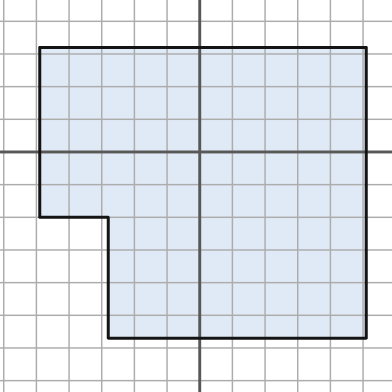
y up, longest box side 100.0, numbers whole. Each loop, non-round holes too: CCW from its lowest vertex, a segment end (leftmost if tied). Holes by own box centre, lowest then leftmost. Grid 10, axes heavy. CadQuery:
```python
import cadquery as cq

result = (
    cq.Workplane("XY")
    .moveTo(-28.0, -57.0)
    .lineTo(51.0, -57.0)
    .lineTo(51.0, 32.0)
    .lineTo(-49.0, 32.0)
    .lineTo(-49.0, -20.0)
    .lineTo(-28.0, -20.0)
    .close()
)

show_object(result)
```